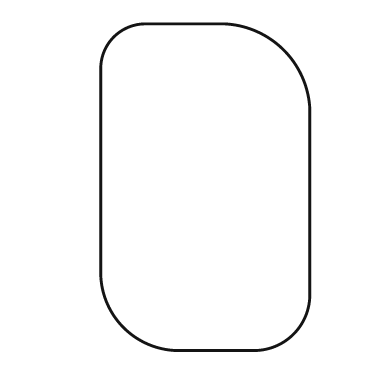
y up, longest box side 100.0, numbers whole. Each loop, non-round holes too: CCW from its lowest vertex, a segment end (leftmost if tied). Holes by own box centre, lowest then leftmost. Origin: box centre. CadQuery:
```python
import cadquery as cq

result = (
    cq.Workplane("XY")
    .moveTo(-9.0, -50.0)
    .lineTo(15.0, -50.0)
    .threePointArc((27.0, -45.0), (32.0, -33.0))
    .lineTo(32.0, 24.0)
    .threePointArc((24.0, 42.0), (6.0, 50.0))
    .lineTo(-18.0, 50.0)
    .threePointArc((-28.0, 46.0), (-32.0, 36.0))
    .lineTo(-32.0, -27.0)
    .threePointArc((-25.0, -43.0), (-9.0, -50.0))
    .close()
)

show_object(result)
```